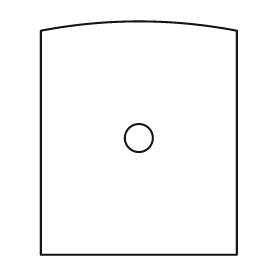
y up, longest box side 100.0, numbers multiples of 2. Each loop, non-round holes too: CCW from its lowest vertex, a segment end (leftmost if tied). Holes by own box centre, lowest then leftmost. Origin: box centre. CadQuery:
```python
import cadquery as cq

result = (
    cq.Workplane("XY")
    .moveTo(-42.0, -50.0)
    .lineTo(42.0, -50.0)
    .lineTo(42.0, 46.0)
    .threePointArc((0.0, 50.0), (-42.0, 46.0))
    .close()
    .moveTo(0.0, 0.0)
    .circle(6.0)
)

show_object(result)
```